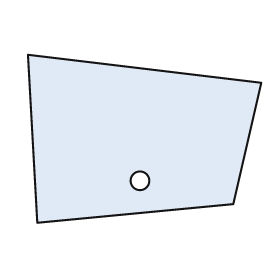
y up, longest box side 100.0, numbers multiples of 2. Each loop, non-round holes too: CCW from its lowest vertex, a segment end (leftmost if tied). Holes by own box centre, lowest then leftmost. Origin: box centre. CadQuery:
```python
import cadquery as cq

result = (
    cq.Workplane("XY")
    .moveTo(-46.0, -36.0)
    .lineTo(38.0, -28.0)
    .lineTo(50.0, 24.0)
    .lineTo(-50.0, 36.0)
    .close()
    .moveTo(-2.0, -18.0)
    .circle(4.0)
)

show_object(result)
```